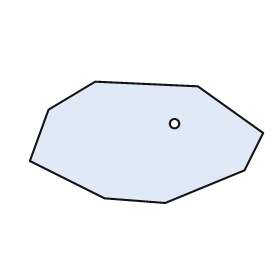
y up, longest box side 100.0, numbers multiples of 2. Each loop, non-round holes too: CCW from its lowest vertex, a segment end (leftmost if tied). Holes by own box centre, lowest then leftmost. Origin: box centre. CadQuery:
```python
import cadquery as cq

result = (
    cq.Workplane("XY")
    .moveTo(8.0, -26.0)
    .lineTo(42.0, -12.0)
    .lineTo(50.0, 4.0)
    .lineTo(22.0, 24.0)
    .lineTo(-22.0, 26.0)
    .lineTo(-42.0, 14.0)
    .lineTo(-50.0, -8.0)
    .lineTo(-18.0, -24.0)
    .close()
    .moveTo(12.0, 8.0)
    .circle(2.0)
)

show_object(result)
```